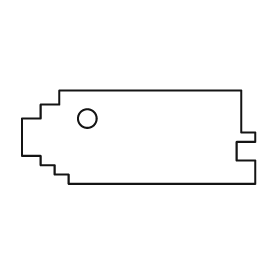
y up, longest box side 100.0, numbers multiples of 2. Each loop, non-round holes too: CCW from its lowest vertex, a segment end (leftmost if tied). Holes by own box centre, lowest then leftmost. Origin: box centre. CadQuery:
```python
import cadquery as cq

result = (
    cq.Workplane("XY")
    .moveTo(-30.0, -20.0)
    .lineTo(50.0, -20.0)
    .lineTo(50.0, -10.0)
    .lineTo(42.0, -10.0)
    .lineTo(42.0, -2.0)
    .lineTo(50.0, -2.0)
    .lineTo(50.0, 2.0)
    .lineTo(44.0, 2.0)
    .lineTo(44.0, 20.0)
    .lineTo(-34.0, 20.0)
    .lineTo(-34.0, 14.0)
    .lineTo(-42.0, 14.0)
    .lineTo(-42.0, 8.0)
    .lineTo(-50.0, 8.0)
    .lineTo(-50.0, -8.0)
    .lineTo(-42.0, -8.0)
    .lineTo(-42.0, -12.0)
    .lineTo(-36.0, -12.0)
    .lineTo(-36.0, -16.0)
    .lineTo(-30.0, -16.0)
    .close()
    .moveTo(-22.0, 8.0)
    .circle(4.0)
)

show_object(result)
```